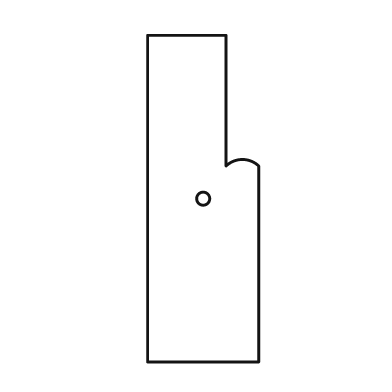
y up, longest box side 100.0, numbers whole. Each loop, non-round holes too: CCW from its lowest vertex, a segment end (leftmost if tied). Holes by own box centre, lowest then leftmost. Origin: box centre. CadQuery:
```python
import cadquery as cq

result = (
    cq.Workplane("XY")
    .moveTo(-17.0, -50.0)
    .lineTo(17.0, -50.0)
    .lineTo(17.0, 10.0)
    .threePointArc((12.0, 12.0), (7.0, 10.0))
    .lineTo(7.0, 50.0)
    .lineTo(-17.0, 50.0)
    .close()
    .moveTo(0.0, 0.0)
    .circle(2.0)
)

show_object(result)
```